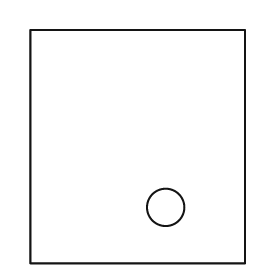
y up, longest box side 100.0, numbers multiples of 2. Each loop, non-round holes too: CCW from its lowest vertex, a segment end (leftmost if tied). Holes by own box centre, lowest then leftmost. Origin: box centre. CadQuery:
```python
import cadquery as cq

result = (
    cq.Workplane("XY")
    .moveTo(-46.0, -50.0)
    .lineTo(46.0, -50.0)
    .lineTo(46.0, 50.0)
    .lineTo(-46.0, 50.0)
    .close()
    .moveTo(12.0, -26.0)
    .circle(8.0)
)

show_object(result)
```